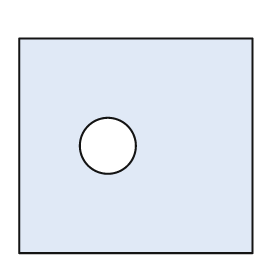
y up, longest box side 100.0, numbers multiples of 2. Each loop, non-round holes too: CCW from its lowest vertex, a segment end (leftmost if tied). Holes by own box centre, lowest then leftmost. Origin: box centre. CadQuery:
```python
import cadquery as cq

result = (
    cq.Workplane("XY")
    .moveTo(-50.0, -46.0)
    .lineTo(50.0, -46.0)
    .lineTo(50.0, 46.0)
    .lineTo(-50.0, 46.0)
    .close()
    .moveTo(-12.0, 0.0)
    .circle(12.0)
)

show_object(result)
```